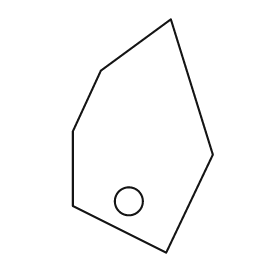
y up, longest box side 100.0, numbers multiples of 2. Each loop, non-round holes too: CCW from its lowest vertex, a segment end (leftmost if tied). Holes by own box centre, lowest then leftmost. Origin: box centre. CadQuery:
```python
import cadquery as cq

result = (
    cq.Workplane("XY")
    .moveTo(10.0, -50.0)
    .lineTo(30.0, -8.0)
    .lineTo(12.0, 50.0)
    .lineTo(-18.0, 28.0)
    .lineTo(-30.0, 2.0)
    .lineTo(-30.0, -30.0)
    .close()
    .moveTo(-6.0, -28.0)
    .circle(6.0)
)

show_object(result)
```